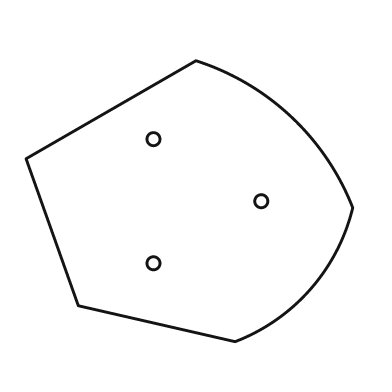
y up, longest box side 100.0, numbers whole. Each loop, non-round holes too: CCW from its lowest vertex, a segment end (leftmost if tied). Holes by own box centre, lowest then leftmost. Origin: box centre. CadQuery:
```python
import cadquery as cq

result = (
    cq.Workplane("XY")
    .moveTo(14.0, -43.0)
    .threePointArc((37.0, -27.0), (50.0, -2.0))
    .threePointArc((31.0, 26.0), (2.0, 43.0))
    .lineTo(-50.0, 13.0)
    .lineTo(-34.0, -32.0)
    .close()
    .moveTo(-11.0, -19.0)
    .circle(2.0)
    .moveTo(22.0, 0.0)
    .circle(2.0)
    .moveTo(-11.0, 19.0)
    .circle(2.0)
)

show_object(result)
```